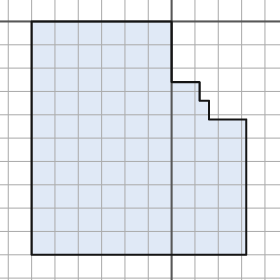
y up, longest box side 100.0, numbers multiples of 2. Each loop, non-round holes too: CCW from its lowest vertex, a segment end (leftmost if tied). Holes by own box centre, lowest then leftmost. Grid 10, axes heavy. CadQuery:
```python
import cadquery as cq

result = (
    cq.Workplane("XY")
    .moveTo(-60.0, -100.0)
    .lineTo(32.0, -100.0)
    .lineTo(32.0, -42.0)
    .lineTo(16.0, -42.0)
    .lineTo(16.0, -34.0)
    .lineTo(12.0, -34.0)
    .lineTo(12.0, -26.0)
    .lineTo(0.0, -26.0)
    .lineTo(0.0, 0.0)
    .lineTo(-60.0, 0.0)
    .close()
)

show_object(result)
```